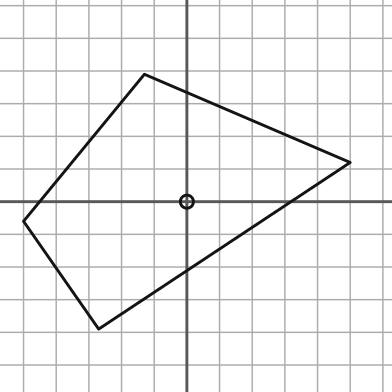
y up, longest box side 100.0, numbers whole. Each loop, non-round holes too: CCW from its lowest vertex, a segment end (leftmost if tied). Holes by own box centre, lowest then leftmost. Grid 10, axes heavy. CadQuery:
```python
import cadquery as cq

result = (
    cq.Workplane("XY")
    .moveTo(-27.0, -39.0)
    .lineTo(50.0, 12.0)
    .lineTo(-13.0, 39.0)
    .lineTo(-50.0, -6.0)
    .close()
    .moveTo(0.0, 0.0)
    .circle(2.0)
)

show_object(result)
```